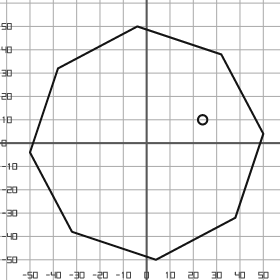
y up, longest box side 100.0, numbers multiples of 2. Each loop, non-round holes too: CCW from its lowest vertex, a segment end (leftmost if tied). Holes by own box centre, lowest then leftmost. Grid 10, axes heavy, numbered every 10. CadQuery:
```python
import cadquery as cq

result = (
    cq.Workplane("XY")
    .moveTo(4.0, -50.0)
    .lineTo(38.0, -32.0)
    .lineTo(50.0, 4.0)
    .lineTo(32.0, 38.0)
    .lineTo(-4.0, 50.0)
    .lineTo(-38.0, 32.0)
    .lineTo(-50.0, -4.0)
    .lineTo(-32.0, -38.0)
    .close()
    .moveTo(24.0, 10.0)
    .circle(2.0)
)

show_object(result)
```